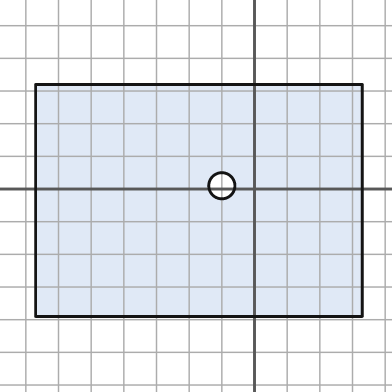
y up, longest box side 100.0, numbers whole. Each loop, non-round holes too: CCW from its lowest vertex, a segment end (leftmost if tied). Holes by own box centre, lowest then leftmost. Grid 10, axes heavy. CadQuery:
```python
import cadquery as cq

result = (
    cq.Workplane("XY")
    .moveTo(-67.0, -39.0)
    .lineTo(33.0, -39.0)
    .lineTo(33.0, 32.0)
    .lineTo(-67.0, 32.0)
    .close()
    .moveTo(-10.0, 1.0)
    .circle(4.0)
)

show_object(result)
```